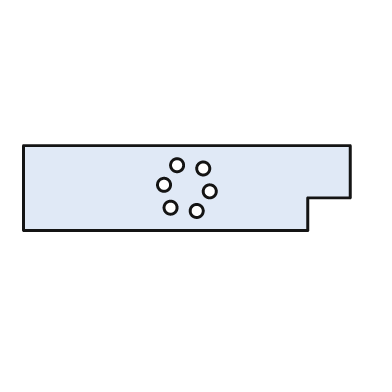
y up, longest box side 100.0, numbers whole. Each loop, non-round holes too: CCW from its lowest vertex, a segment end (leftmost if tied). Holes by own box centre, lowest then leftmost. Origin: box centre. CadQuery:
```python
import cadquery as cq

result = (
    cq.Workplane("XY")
    .moveTo(-50.0, -13.0)
    .lineTo(37.0, -13.0)
    .lineTo(37.0, -3.0)
    .lineTo(50.0, -3.0)
    .lineTo(50.0, 13.0)
    .lineTo(-50.0, 13.0)
    .close()
    .moveTo(3.0, -7.0)
    .circle(2.0)
    .moveTo(-5.0, -6.0)
    .circle(2.0)
    .moveTo(7.0, -1.0)
    .circle(2.0)
    .moveTo(-7.0, 1.0)
    .circle(2.0)
    .moveTo(5.0, 6.0)
    .circle(2.0)
    .moveTo(-3.0, 7.0)
    .circle(2.0)
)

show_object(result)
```